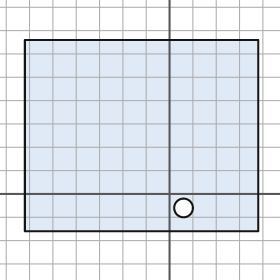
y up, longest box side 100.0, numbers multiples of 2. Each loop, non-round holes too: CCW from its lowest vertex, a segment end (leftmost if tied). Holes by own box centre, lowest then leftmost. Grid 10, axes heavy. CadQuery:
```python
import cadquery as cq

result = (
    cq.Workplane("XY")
    .moveTo(-62.0, -16.0)
    .lineTo(38.0, -16.0)
    .lineTo(38.0, 66.0)
    .lineTo(-62.0, 66.0)
    .close()
    .moveTo(6.0, -6.0)
    .circle(4.0)
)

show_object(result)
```